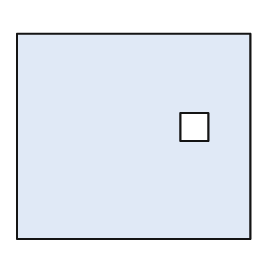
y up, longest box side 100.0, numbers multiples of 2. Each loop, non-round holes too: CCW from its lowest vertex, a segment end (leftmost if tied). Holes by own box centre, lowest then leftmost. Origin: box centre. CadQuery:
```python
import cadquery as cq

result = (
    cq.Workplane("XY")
    .moveTo(-50.0, -44.0)
    .lineTo(50.0, -44.0)
    .lineTo(50.0, 44.0)
    .lineTo(-50.0, 44.0)
    .close()
    .moveTo(20.0, -2.0)
    .lineTo(32.0, -2.0)
    .lineTo(32.0, 10.0)
    .lineTo(20.0, 10.0)
    .close()
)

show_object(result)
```